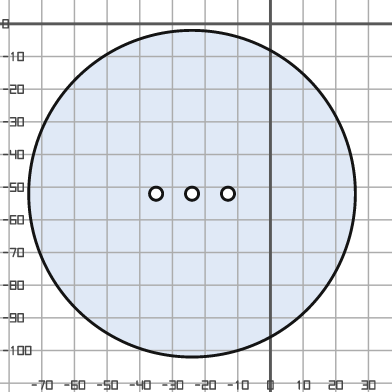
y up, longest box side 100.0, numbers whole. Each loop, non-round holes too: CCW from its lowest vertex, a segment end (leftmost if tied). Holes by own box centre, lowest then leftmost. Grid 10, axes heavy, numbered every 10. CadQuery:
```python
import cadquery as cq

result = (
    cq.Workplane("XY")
    .moveTo(-24.0, -52.0)
    .circle(50.0)
    .moveTo(-35.0, -52.0)
    .circle(2.0)
    .moveTo(-24.0, -52.0)
    .circle(2.0)
    .moveTo(-13.0, -52.0)
    .circle(2.0)
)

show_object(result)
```